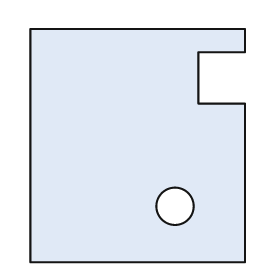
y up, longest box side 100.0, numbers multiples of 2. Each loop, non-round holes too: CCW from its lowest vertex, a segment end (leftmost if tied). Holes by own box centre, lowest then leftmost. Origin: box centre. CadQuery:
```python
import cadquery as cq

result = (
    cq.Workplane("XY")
    .moveTo(-46.0, -50.0)
    .lineTo(46.0, -50.0)
    .lineTo(46.0, 18.0)
    .lineTo(26.0, 18.0)
    .lineTo(26.0, 40.0)
    .lineTo(46.0, 40.0)
    .lineTo(46.0, 50.0)
    .lineTo(-46.0, 50.0)
    .close()
    .moveTo(16.0, -26.0)
    .circle(8.0)
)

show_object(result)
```